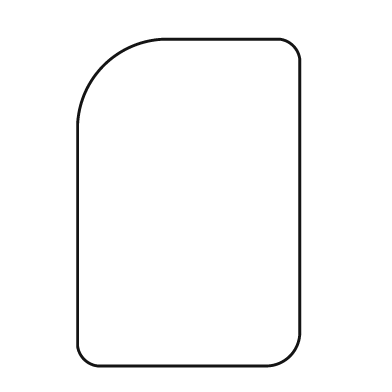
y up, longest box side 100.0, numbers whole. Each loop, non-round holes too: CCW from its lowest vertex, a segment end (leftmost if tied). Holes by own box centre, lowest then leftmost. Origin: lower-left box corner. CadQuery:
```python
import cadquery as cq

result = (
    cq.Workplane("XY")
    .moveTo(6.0, 0.0)
    .lineTo(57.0, 0.0)
    .threePointArc((65.0, 3.0), (68.0, 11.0))
    .lineTo(68.0, 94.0)
    .threePointArc((66.0, 98.0), (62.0, 100.0))
    .lineTo(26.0, 100.0)
    .threePointArc((8.0, 92.0), (0.0, 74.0))
    .lineTo(0.0, 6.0)
    .threePointArc((2.0, 2.0), (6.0, 0.0))
    .close()
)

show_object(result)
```